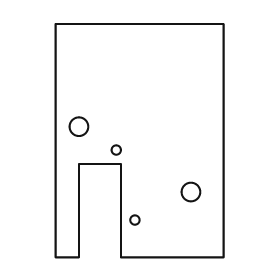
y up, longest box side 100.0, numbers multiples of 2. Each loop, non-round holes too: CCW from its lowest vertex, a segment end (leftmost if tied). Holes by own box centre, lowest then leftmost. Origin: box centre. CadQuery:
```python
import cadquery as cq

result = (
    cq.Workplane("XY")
    .moveTo(-36.0, -50.0)
    .lineTo(-26.0, -50.0)
    .lineTo(-26.0, -10.0)
    .lineTo(-8.0, -10.0)
    .lineTo(-8.0, -50.0)
    .lineTo(36.0, -50.0)
    .lineTo(36.0, 50.0)
    .lineTo(-36.0, 50.0)
    .close()
    .moveTo(-2.0, -34.0)
    .circle(2.0)
    .moveTo(22.0, -22.0)
    .circle(4.0)
    .moveTo(-10.0, -4.0)
    .circle(2.0)
    .moveTo(-26.0, 6.0)
    .circle(4.0)
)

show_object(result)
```